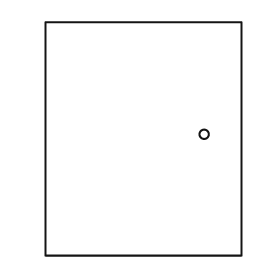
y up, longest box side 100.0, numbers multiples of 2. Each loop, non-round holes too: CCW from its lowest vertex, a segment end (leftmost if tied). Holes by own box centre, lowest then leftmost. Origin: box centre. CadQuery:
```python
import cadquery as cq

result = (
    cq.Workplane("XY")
    .moveTo(-42.0, -50.0)
    .lineTo(42.0, -50.0)
    .lineTo(42.0, 50.0)
    .lineTo(-42.0, 50.0)
    .close()
    .moveTo(26.0, 2.0)
    .circle(2.0)
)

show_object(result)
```